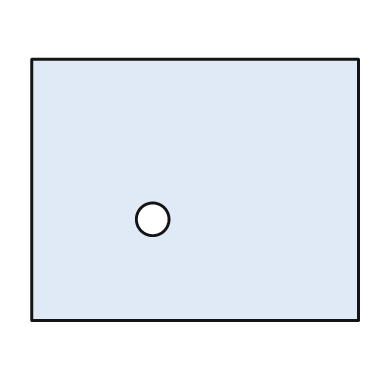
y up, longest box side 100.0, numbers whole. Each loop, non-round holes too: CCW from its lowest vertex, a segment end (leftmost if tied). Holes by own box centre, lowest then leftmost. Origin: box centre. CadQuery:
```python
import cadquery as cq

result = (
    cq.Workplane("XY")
    .moveTo(-50.0, -40.0)
    .lineTo(50.0, -40.0)
    .lineTo(50.0, 40.0)
    .lineTo(-50.0, 40.0)
    .close()
    .moveTo(-13.0, -9.0)
    .circle(5.0)
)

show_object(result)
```